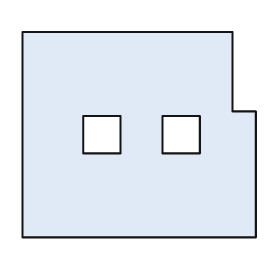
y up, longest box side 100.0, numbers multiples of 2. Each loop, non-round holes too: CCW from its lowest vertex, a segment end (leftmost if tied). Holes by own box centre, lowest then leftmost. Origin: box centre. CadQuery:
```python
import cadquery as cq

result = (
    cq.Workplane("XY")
    .moveTo(-50.0, -44.0)
    .lineTo(50.0, -44.0)
    .lineTo(50.0, 10.0)
    .lineTo(40.0, 10.0)
    .lineTo(40.0, 44.0)
    .lineTo(-50.0, 44.0)
    .close()
    .moveTo(-24.0, -8.0)
    .lineTo(-8.0, -8.0)
    .lineTo(-8.0, 8.0)
    .lineTo(-24.0, 8.0)
    .close()
    .moveTo(10.0, -8.0)
    .lineTo(26.0, -8.0)
    .lineTo(26.0, 8.0)
    .lineTo(10.0, 8.0)
    .close()
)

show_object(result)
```